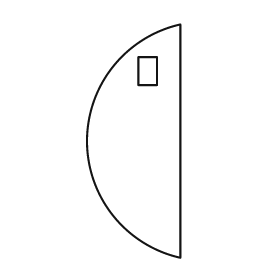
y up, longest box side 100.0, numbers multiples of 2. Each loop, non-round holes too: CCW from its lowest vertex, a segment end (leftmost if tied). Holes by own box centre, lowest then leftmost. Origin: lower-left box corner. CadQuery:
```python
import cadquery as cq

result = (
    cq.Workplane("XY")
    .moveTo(40.0, 0.0)
    .lineTo(40.0, 100.0)
    .threePointArc((0.0, 50.0), (40.0, 0.0))
    .close()
    .moveTo(22.0, 74.0)
    .lineTo(30.0, 74.0)
    .lineTo(30.0, 86.0)
    .lineTo(22.0, 86.0)
    .close()
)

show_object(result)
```